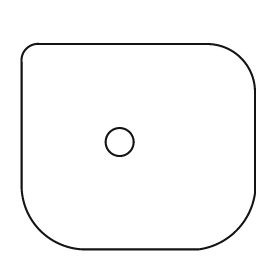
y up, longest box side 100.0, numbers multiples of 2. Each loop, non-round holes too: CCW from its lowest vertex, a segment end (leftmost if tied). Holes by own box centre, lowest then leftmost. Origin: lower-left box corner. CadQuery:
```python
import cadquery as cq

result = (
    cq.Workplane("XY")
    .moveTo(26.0, 0.0)
    .lineTo(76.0, 0.0)
    .threePointArc((92.0, 8.0), (100.0, 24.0))
    .lineTo(100.0, 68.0)
    .threePointArc((94.0, 82.0), (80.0, 88.0))
    .lineTo(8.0, 88.0)
    .threePointArc((2.0, 86.0), (0.0, 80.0))
    .lineTo(0.0, 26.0)
    .threePointArc((8.0, 8.0), (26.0, 0.0))
    .close()
    .moveTo(42.0, 46.0)
    .circle(6.0)
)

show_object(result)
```